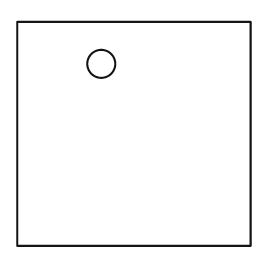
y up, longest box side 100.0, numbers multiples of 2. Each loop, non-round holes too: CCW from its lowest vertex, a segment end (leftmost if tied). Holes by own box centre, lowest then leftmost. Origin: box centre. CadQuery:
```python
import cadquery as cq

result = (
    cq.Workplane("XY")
    .moveTo(-50.0, -48.0)
    .lineTo(50.0, -48.0)
    .lineTo(50.0, 48.0)
    .lineTo(-50.0, 48.0)
    .close()
    .moveTo(-14.0, 30.0)
    .circle(6.0)
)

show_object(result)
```